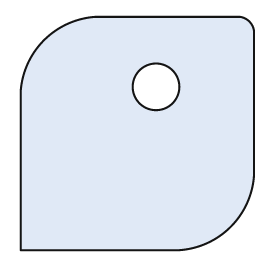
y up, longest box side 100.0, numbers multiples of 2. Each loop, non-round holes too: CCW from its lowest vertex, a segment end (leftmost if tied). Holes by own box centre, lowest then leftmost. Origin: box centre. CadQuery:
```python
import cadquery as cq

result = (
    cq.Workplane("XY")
    .moveTo(-50.0, -50.0)
    .lineTo(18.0, -50.0)
    .threePointArc((40.0, -40.0), (50.0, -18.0))
    .lineTo(50.0, 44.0)
    .threePointArc((48.0, 48.0), (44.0, 50.0))
    .lineTo(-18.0, 50.0)
    .threePointArc((-40.0, 40.0), (-50.0, 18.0))
    .close()
    .moveTo(8.0, 20.0)
    .circle(10.0)
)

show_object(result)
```